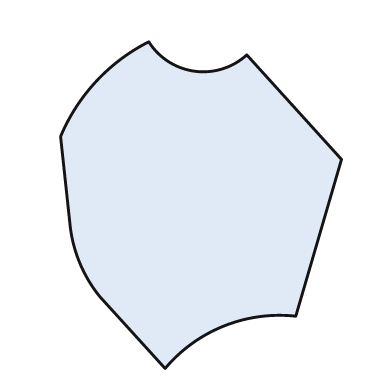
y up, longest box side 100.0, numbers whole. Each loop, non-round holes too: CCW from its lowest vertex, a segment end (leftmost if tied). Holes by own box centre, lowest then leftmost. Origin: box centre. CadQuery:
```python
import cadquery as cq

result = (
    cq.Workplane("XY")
    .moveTo(-11.0, -50.0)
    .threePointArc((7.0, -37.0), (29.0, -34.0))
    .lineTo(43.0, 14.0)
    .lineTo(14.0, 46.0)
    .threePointArc((-2.0, 41.0), (-16.0, 50.0))
    .threePointArc((-32.0, 38.0), (-43.0, 21.0))
    .lineTo(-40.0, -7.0)
    .threePointArc((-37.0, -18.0), (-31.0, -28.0))
    .close()
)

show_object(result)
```